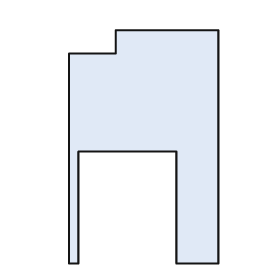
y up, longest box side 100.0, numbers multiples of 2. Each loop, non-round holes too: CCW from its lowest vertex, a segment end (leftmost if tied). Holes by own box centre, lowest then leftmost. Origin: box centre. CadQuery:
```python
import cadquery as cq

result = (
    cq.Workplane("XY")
    .moveTo(-32.0, -50.0)
    .lineTo(-28.0, -50.0)
    .lineTo(-28.0, -2.0)
    .lineTo(14.0, -2.0)
    .lineTo(14.0, -50.0)
    .lineTo(32.0, -50.0)
    .lineTo(32.0, 50.0)
    .lineTo(-12.0, 50.0)
    .lineTo(-12.0, 40.0)
    .lineTo(-32.0, 40.0)
    .close()
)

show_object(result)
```